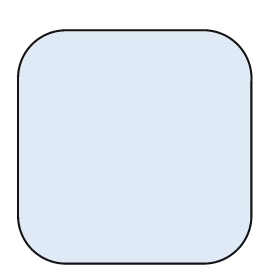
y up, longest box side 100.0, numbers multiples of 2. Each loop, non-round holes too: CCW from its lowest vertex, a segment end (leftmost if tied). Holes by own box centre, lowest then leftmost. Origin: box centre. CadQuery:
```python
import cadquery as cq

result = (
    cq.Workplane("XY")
    .moveTo(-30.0, -50.0)
    .lineTo(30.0, -50.0)
    .threePointArc((44.0, -44.0), (50.0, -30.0))
    .lineTo(50.0, 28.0)
    .threePointArc((44.0, 44.0), (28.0, 50.0))
    .lineTo(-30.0, 50.0)
    .threePointArc((-44.0, 44.0), (-50.0, 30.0))
    .lineTo(-50.0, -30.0)
    .threePointArc((-44.0, -44.0), (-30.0, -50.0))
    .close()
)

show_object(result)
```